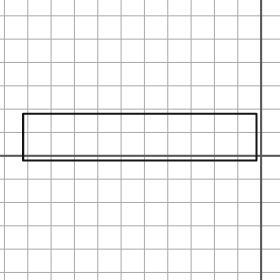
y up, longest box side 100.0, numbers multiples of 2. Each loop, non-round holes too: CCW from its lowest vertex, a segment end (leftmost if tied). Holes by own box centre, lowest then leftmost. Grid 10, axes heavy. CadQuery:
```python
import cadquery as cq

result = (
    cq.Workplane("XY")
    .moveTo(-102.0, -2.0)
    .lineTo(-2.0, -2.0)
    .lineTo(-2.0, 18.0)
    .lineTo(-102.0, 18.0)
    .close()
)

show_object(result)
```